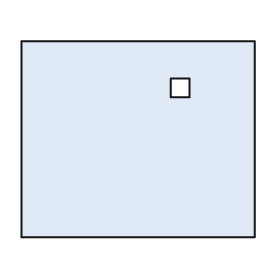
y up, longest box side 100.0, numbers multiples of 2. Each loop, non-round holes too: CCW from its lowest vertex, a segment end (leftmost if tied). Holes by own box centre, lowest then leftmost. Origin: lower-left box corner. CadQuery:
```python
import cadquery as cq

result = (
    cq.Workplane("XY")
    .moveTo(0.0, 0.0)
    .lineTo(100.0, 0.0)
    .lineTo(100.0, 84.0)
    .lineTo(0.0, 84.0)
    .close()
    .moveTo(64.0, 60.0)
    .lineTo(72.0, 60.0)
    .lineTo(72.0, 68.0)
    .lineTo(64.0, 68.0)
    .close()
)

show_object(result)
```